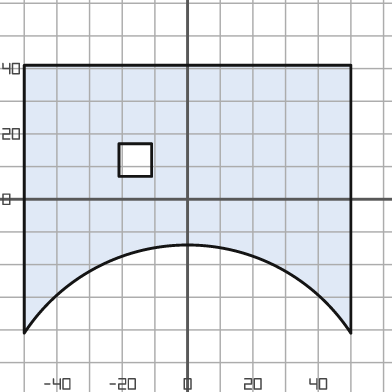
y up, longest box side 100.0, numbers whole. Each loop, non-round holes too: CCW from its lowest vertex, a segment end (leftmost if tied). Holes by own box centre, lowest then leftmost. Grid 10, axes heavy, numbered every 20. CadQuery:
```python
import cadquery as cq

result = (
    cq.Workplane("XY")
    .moveTo(-50.0, -41.0)
    .threePointArc((0.0, -14.0), (50.0, -41.0))
    .lineTo(50.0, 41.0)
    .lineTo(-50.0, 41.0)
    .close()
    .moveTo(-21.0, 7.0)
    .lineTo(-11.0, 7.0)
    .lineTo(-11.0, 17.0)
    .lineTo(-21.0, 17.0)
    .close()
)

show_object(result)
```